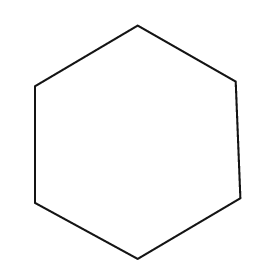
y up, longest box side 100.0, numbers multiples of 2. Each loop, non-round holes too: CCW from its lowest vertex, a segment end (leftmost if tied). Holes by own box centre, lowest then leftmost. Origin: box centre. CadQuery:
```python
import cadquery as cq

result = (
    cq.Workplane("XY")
    .moveTo(0.0, -50.0)
    .lineTo(44.0, -24.0)
    .lineTo(42.0, 26.0)
    .lineTo(0.0, 50.0)
    .lineTo(-44.0, 24.0)
    .lineTo(-44.0, -26.0)
    .close()
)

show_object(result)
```